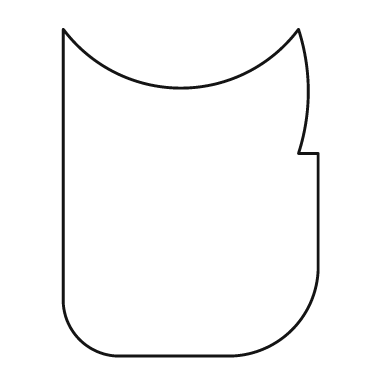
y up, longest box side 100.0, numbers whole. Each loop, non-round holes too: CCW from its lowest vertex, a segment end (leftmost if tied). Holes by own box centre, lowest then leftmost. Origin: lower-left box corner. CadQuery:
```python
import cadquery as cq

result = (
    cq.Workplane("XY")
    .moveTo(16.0, 0.0)
    .lineTo(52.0, 0.0)
    .threePointArc((70.0, 8.0), (78.0, 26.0))
    .lineTo(78.0, 62.0)
    .lineTo(72.0, 62.0)
    .threePointArc((75.0, 81.0), (72.0, 100.0))
    .threePointArc((36.0, 82.0), (0.0, 100.0))
    .lineTo(0.0, 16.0)
    .threePointArc((5.0, 5.0), (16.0, 0.0))
    .close()
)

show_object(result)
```